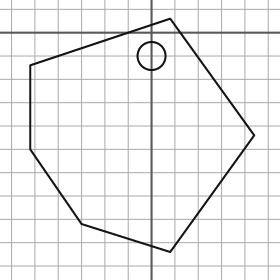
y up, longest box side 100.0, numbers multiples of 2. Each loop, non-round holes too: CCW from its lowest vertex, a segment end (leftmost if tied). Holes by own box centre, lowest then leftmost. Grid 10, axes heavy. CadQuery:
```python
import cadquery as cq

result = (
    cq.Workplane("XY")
    .moveTo(8.0, -94.0)
    .lineTo(44.0, -44.0)
    .lineTo(8.0, 6.0)
    .lineTo(-52.0, -14.0)
    .lineTo(-52.0, -50.0)
    .lineTo(-30.0, -82.0)
    .close()
    .moveTo(0.0, -10.0)
    .circle(6.0)
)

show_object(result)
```